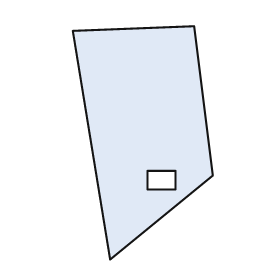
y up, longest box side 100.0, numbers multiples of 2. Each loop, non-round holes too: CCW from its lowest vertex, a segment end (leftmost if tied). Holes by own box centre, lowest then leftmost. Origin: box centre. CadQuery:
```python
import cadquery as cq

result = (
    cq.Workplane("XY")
    .moveTo(-14.0, -50.0)
    .lineTo(30.0, -14.0)
    .lineTo(22.0, 50.0)
    .lineTo(-30.0, 48.0)
    .close()
    .moveTo(2.0, -20.0)
    .lineTo(14.0, -20.0)
    .lineTo(14.0, -12.0)
    .lineTo(2.0, -12.0)
    .close()
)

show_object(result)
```